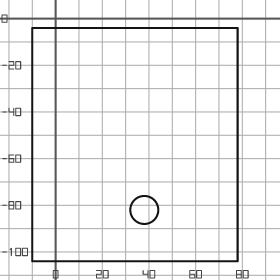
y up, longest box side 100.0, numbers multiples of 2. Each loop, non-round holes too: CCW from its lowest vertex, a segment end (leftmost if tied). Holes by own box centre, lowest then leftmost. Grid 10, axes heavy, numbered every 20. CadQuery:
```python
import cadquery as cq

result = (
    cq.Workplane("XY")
    .moveTo(-10.0, -104.0)
    .lineTo(78.0, -104.0)
    .lineTo(78.0, -4.0)
    .lineTo(-10.0, -4.0)
    .close()
    .moveTo(38.0, -82.0)
    .circle(6.0)
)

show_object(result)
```